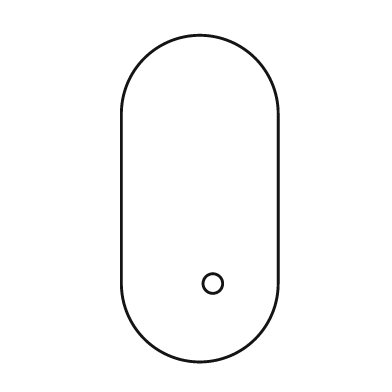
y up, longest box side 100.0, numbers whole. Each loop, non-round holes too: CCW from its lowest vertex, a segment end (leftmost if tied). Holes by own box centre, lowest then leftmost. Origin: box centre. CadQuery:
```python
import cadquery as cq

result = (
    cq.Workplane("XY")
    .moveTo(-24.0, -26.0)
    .threePointArc((0.0, -50.0), (24.0, -26.0))
    .lineTo(24.0, 26.0)
    .threePointArc((0.0, 50.0), (-24.0, 26.0))
    .close()
    .moveTo(4.0, -26.0)
    .circle(3.0)
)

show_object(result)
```